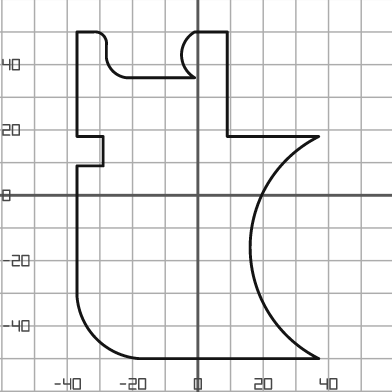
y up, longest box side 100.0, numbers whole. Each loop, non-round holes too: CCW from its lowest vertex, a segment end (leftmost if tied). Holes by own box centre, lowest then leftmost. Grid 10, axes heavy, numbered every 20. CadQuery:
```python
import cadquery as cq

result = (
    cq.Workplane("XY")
    .moveTo(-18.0, -50.0)
    .lineTo(37.0, -50.0)
    .threePointArc((16.0, -16.0), (37.0, 18.0))
    .lineTo(9.0, 18.0)
    .lineTo(9.0, 50.0)
    .lineTo(-1.0, 50.0)
    .threePointArc((-5.0, 43.0), (-1.0, 36.0))
    .lineTo(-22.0, 36.0)
    .threePointArc((-26.0, 38.0), (-28.0, 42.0))
    .lineTo(-28.0, 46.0)
    .threePointArc((-29.0, 49.0), (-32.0, 50.0))
    .lineTo(-37.0, 50.0)
    .lineTo(-37.0, 18.0)
    .lineTo(-29.0, 18.0)
    .lineTo(-29.0, 9.0)
    .lineTo(-37.0, 9.0)
    .lineTo(-37.0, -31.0)
    .threePointArc((-31.0, -44.0), (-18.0, -50.0))
    .close()
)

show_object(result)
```